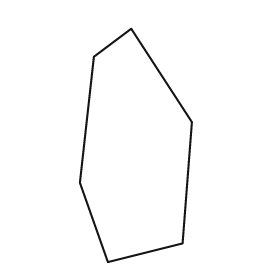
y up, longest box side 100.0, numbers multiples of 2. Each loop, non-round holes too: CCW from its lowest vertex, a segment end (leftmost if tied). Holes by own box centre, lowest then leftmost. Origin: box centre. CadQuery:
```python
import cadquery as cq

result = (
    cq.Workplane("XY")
    .moveTo(-12.0, -50.0)
    .lineTo(20.0, -42.0)
    .lineTo(24.0, 10.0)
    .lineTo(-2.0, 50.0)
    .lineTo(-18.0, 38.0)
    .lineTo(-24.0, -16.0)
    .close()
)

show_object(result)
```